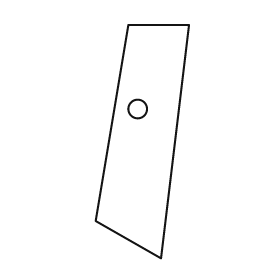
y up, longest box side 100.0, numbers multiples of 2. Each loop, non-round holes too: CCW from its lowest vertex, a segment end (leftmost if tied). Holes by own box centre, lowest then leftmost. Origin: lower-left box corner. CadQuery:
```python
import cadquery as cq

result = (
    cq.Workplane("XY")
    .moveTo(28.0, 0.0)
    .lineTo(40.0, 100.0)
    .lineTo(14.0, 100.0)
    .lineTo(0.0, 16.0)
    .close()
    .moveTo(18.0, 64.0)
    .circle(4.0)
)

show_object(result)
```